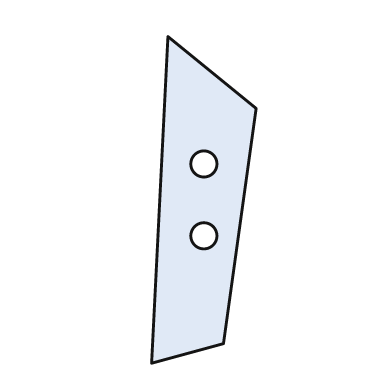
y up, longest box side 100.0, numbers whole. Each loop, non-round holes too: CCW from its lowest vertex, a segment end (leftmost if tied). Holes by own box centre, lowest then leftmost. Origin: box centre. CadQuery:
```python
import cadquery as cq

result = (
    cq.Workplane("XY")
    .moveTo(-16.0, -50.0)
    .lineTo(6.0, -44.0)
    .lineTo(16.0, 28.0)
    .lineTo(-11.0, 50.0)
    .close()
    .moveTo(0.0, -11.0)
    .circle(4.0)
    .moveTo(0.0, 11.0)
    .circle(4.0)
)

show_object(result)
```